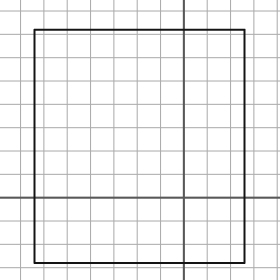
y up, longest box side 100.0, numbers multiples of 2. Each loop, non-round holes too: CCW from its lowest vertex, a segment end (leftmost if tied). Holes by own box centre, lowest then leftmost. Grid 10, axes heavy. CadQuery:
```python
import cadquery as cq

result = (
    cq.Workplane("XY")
    .moveTo(-64.0, -28.0)
    .lineTo(26.0, -28.0)
    .lineTo(26.0, 72.0)
    .lineTo(-64.0, 72.0)
    .close()
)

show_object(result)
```